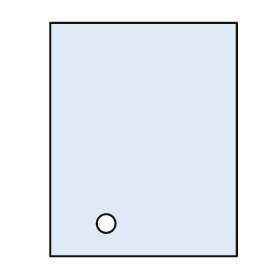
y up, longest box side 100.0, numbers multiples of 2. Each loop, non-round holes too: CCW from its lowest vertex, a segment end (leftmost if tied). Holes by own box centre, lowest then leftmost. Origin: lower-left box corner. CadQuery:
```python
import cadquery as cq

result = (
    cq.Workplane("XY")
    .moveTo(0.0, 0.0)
    .lineTo(80.0, 0.0)
    .lineTo(80.0, 100.0)
    .lineTo(0.0, 100.0)
    .close()
    .moveTo(24.0, 14.0)
    .circle(4.0)
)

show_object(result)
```